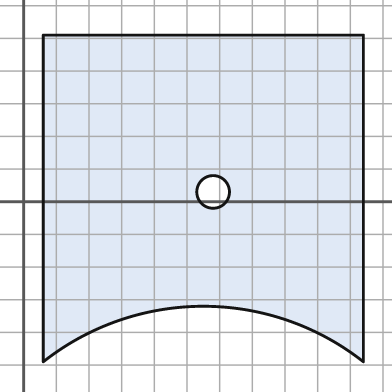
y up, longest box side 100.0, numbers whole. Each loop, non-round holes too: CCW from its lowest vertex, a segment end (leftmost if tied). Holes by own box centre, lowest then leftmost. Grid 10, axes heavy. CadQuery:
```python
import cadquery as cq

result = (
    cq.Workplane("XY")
    .moveTo(6.0, -49.0)
    .threePointArc((55.0, -32.0), (104.0, -49.0))
    .lineTo(104.0, 51.0)
    .lineTo(6.0, 51.0)
    .close()
    .moveTo(58.0, 3.0)
    .circle(5.0)
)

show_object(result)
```